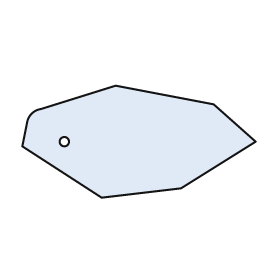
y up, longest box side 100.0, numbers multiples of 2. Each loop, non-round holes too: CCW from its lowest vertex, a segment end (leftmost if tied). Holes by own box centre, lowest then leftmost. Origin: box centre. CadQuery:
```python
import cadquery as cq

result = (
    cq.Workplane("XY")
    .moveTo(-16.0, -24.0)
    .lineTo(18.0, -20.0)
    .lineTo(50.0, 0.0)
    .lineTo(32.0, 16.0)
    .lineTo(-10.0, 24.0)
    .lineTo(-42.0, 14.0)
    .threePointArc((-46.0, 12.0), (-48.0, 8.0))
    .lineTo(-50.0, -2.0)
    .close()
    .moveTo(-32.0, 0.0)
    .circle(2.0)
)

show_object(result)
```